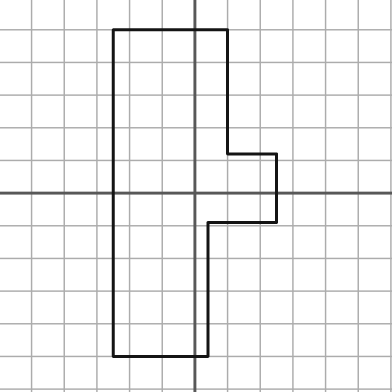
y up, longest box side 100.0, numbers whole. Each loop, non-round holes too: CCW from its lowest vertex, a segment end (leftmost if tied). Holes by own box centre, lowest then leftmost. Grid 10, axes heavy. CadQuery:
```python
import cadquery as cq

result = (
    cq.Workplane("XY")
    .moveTo(-25.0, -50.0)
    .lineTo(4.0, -50.0)
    .lineTo(4.0, -9.0)
    .lineTo(25.0, -9.0)
    .lineTo(25.0, 12.0)
    .lineTo(10.0, 12.0)
    .lineTo(10.0, 50.0)
    .lineTo(-25.0, 50.0)
    .close()
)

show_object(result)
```